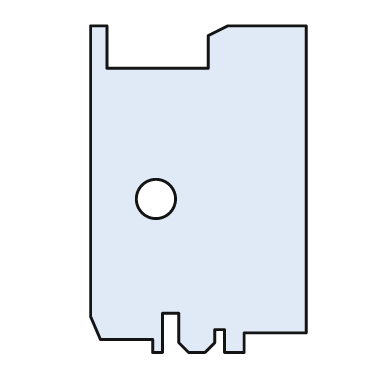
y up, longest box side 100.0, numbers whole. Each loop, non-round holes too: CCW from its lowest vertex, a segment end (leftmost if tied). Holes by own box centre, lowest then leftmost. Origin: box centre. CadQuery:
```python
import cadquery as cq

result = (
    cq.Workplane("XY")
    .moveTo(-14.0, -50.0)
    .lineTo(-11.0, -50.0)
    .lineTo(-11.0, -38.0)
    .lineTo(-6.0, -38.0)
    .lineTo(-6.0, -47.0)
    .lineTo(-3.0, -50.0)
    .lineTo(2.0, -50.0)
    .lineTo(5.0, -47.0)
    .lineTo(5.0, -43.0)
    .lineTo(8.0, -43.0)
    .lineTo(8.0, -50.0)
    .lineTo(14.0, -50.0)
    .lineTo(14.0, -44.0)
    .lineTo(33.0, -44.0)
    .lineTo(33.0, 50.0)
    .lineTo(9.0, 50.0)
    .lineTo(3.0, 47.0)
    .lineTo(3.0, 37.0)
    .lineTo(-28.0, 37.0)
    .lineTo(-28.0, 50.0)
    .lineTo(-33.0, 50.0)
    .lineTo(-33.0, -39.0)
    .lineTo(-30.0, -46.0)
    .lineTo(-14.0, -46.0)
    .close()
    .moveTo(-13.0, -3.0)
    .circle(6.0)
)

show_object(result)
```